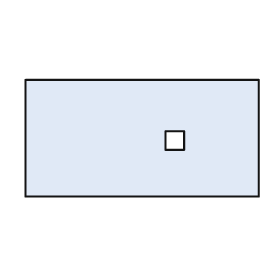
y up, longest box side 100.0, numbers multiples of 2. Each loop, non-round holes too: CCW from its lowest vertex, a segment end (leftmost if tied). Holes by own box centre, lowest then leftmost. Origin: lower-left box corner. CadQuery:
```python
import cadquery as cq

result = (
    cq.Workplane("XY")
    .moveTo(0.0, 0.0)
    .lineTo(100.0, 0.0)
    .lineTo(100.0, 50.0)
    .lineTo(0.0, 50.0)
    .close()
    .moveTo(60.0, 20.0)
    .lineTo(68.0, 20.0)
    .lineTo(68.0, 28.0)
    .lineTo(60.0, 28.0)
    .close()
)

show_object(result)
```